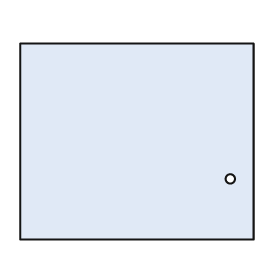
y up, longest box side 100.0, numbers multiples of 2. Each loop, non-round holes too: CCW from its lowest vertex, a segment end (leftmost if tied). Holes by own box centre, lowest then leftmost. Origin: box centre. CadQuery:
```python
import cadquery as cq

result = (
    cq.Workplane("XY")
    .moveTo(-50.0, -42.0)
    .lineTo(50.0, -42.0)
    .lineTo(50.0, 42.0)
    .lineTo(-50.0, 42.0)
    .close()
    .moveTo(40.0, -16.0)
    .circle(2.0)
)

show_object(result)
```